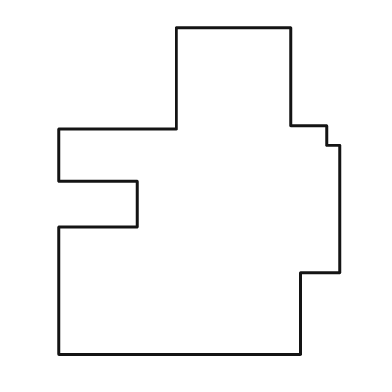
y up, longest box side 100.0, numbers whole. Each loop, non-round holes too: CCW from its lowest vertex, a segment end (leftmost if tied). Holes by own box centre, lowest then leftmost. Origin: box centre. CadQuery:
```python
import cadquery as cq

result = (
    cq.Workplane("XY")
    .moveTo(-43.0, -50.0)
    .lineTo(31.0, -50.0)
    .lineTo(31.0, -25.0)
    .lineTo(43.0, -25.0)
    .lineTo(43.0, 14.0)
    .lineTo(39.0, 14.0)
    .lineTo(39.0, 20.0)
    .lineTo(28.0, 20.0)
    .lineTo(28.0, 50.0)
    .lineTo(-7.0, 50.0)
    .lineTo(-7.0, 19.0)
    .lineTo(-43.0, 19.0)
    .lineTo(-43.0, 3.0)
    .lineTo(-19.0, 3.0)
    .lineTo(-19.0, -11.0)
    .lineTo(-43.0, -11.0)
    .close()
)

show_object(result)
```